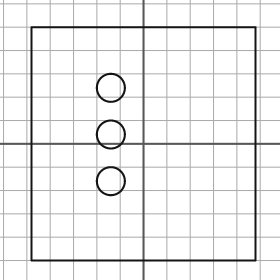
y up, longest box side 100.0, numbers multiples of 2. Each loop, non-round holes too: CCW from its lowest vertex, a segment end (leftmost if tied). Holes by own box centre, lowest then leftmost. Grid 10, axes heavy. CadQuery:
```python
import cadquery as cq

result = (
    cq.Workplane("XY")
    .moveTo(-48.0, -50.0)
    .lineTo(48.0, -50.0)
    .lineTo(48.0, 50.0)
    .lineTo(-48.0, 50.0)
    .close()
    .moveTo(-14.0, -16.0)
    .circle(6.0)
    .moveTo(-14.0, 4.0)
    .circle(6.0)
    .moveTo(-14.0, 24.0)
    .circle(6.0)
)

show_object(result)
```